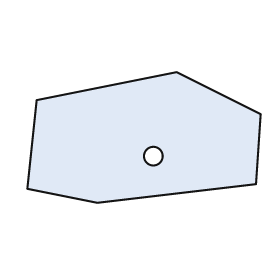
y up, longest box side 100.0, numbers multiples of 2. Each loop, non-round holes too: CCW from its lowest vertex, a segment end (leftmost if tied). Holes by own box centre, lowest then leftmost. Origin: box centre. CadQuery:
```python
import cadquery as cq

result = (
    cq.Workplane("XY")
    .moveTo(-20.0, -28.0)
    .lineTo(48.0, -20.0)
    .lineTo(50.0, 10.0)
    .lineTo(14.0, 28.0)
    .lineTo(-46.0, 16.0)
    .lineTo(-50.0, -22.0)
    .close()
    .moveTo(4.0, -8.0)
    .circle(4.0)
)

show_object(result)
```